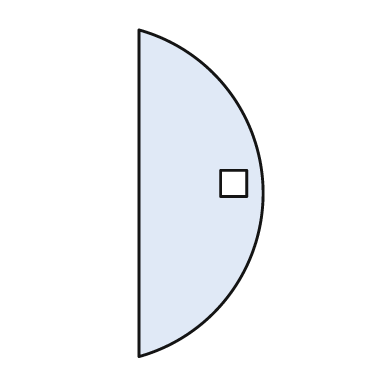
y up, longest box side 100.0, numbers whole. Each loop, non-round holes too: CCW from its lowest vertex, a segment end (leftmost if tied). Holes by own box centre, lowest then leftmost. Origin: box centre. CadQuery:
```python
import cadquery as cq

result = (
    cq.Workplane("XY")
    .moveTo(-19.0, -50.0)
    .threePointArc((19.0, 0.0), (-19.0, 50.0))
    .close()
    .moveTo(6.0, -1.0)
    .lineTo(14.0, -1.0)
    .lineTo(14.0, 7.0)
    .lineTo(6.0, 7.0)
    .close()
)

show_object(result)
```